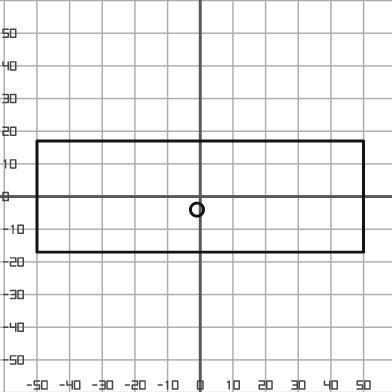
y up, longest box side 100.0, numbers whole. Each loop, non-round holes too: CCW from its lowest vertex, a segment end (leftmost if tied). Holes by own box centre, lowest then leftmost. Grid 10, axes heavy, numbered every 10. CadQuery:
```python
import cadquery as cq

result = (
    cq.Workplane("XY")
    .moveTo(-50.0, -17.0)
    .lineTo(50.0, -17.0)
    .lineTo(50.0, 17.0)
    .lineTo(-50.0, 17.0)
    .close()
    .moveTo(-1.0, -4.0)
    .circle(2.0)
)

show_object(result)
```